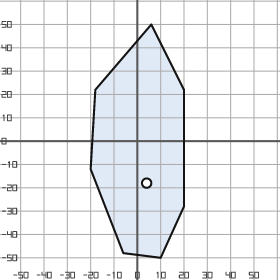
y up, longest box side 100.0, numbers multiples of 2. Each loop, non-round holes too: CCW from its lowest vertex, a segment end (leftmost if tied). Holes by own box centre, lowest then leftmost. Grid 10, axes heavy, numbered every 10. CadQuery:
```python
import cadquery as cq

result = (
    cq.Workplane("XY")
    .moveTo(10.0, -50.0)
    .lineTo(20.0, -28.0)
    .lineTo(20.0, 22.0)
    .lineTo(6.0, 50.0)
    .lineTo(-18.0, 22.0)
    .lineTo(-20.0, -12.0)
    .lineTo(-6.0, -48.0)
    .close()
    .moveTo(4.0, -18.0)
    .circle(2.0)
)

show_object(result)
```